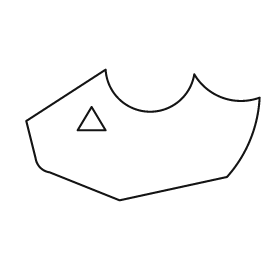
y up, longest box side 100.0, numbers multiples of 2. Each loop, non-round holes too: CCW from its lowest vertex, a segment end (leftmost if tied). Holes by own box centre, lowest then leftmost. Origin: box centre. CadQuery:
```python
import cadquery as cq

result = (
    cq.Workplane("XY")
    .moveTo(-10.0, -28.0)
    .lineTo(36.0, -18.0)
    .threePointArc((46.0, -2.0), (50.0, 16.0))
    .threePointArc((34.0, 16.0), (22.0, 26.0))
    .threePointArc((2.0, 10.0), (-16.0, 28.0))
    .lineTo(-50.0, 6.0)
    .lineTo(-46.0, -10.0)
    .threePointArc((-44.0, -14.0), (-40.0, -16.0))
    .close()
    .moveTo(-28.0, 2.0)
    .lineTo(-16.0, 2.0)
    .lineTo(-22.0, 12.0)
    .close()
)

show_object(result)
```